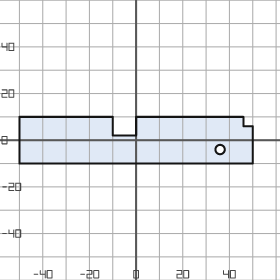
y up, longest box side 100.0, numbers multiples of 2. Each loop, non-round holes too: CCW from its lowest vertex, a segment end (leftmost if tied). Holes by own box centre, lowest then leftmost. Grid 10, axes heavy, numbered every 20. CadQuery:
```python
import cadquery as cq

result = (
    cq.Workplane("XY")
    .moveTo(-50.0, -10.0)
    .lineTo(50.0, -10.0)
    .lineTo(50.0, 6.0)
    .lineTo(46.0, 6.0)
    .lineTo(46.0, 10.0)
    .lineTo(0.0, 10.0)
    .lineTo(0.0, 2.0)
    .lineTo(-10.0, 2.0)
    .lineTo(-10.0, 10.0)
    .lineTo(-50.0, 10.0)
    .close()
    .moveTo(36.0, -4.0)
    .circle(2.0)
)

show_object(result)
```